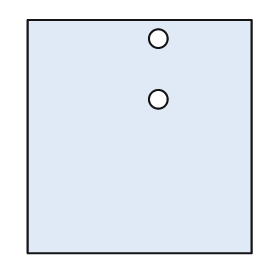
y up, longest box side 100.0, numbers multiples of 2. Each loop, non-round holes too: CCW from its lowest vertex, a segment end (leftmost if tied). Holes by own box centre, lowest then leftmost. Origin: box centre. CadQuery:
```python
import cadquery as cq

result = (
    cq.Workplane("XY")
    .moveTo(-48.0, -50.0)
    .lineTo(48.0, -50.0)
    .lineTo(48.0, 50.0)
    .lineTo(-48.0, 50.0)
    .close()
    .moveTo(8.0, 16.0)
    .circle(4.0)
    .moveTo(8.0, 42.0)
    .circle(4.0)
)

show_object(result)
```